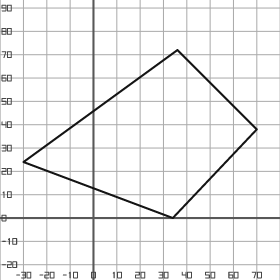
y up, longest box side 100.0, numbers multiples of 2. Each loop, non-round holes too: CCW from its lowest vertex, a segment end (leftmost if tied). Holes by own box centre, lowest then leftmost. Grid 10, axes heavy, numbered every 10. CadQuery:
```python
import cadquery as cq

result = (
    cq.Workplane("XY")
    .moveTo(34.0, 0.0)
    .lineTo(70.0, 38.0)
    .lineTo(36.0, 72.0)
    .lineTo(-30.0, 24.0)
    .close()
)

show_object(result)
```